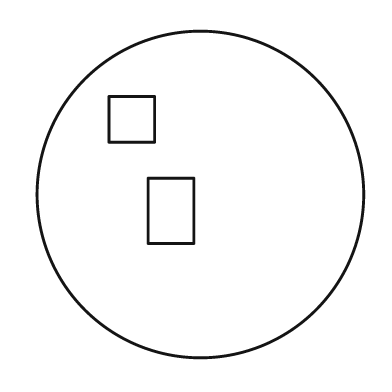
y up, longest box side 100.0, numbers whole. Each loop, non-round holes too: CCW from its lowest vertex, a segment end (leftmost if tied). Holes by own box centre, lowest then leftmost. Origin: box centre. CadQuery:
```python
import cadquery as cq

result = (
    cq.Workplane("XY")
    .moveTo(0.0, 0.0)
    .circle(50.0)
    .moveTo(-16.0, -15.0)
    .lineTo(-2.0, -15.0)
    .lineTo(-2.0, 5.0)
    .lineTo(-16.0, 5.0)
    .close()
    .moveTo(-28.0, 16.0)
    .lineTo(-14.0, 16.0)
    .lineTo(-14.0, 30.0)
    .lineTo(-28.0, 30.0)
    .close()
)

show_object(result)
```